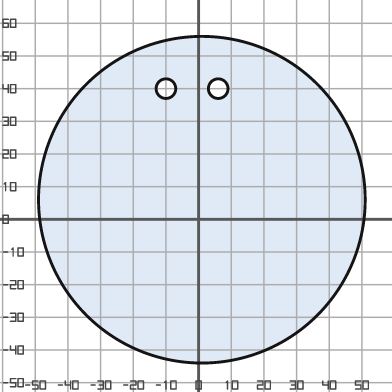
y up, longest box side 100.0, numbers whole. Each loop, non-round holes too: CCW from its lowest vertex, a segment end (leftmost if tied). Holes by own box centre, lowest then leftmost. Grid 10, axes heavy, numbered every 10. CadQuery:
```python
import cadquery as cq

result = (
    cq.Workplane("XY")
    .moveTo(1.0, 6.0)
    .circle(50.0)
    .moveTo(-10.0, 40.0)
    .circle(3.0)
    .moveTo(6.0, 40.0)
    .circle(3.0)
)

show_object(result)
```